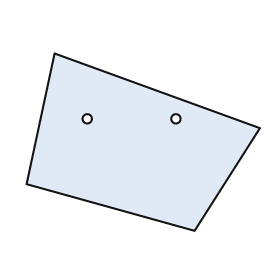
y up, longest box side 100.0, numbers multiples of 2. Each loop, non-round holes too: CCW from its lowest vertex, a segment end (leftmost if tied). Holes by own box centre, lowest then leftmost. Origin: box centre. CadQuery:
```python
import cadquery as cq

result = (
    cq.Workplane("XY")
    .moveTo(22.0, -38.0)
    .lineTo(50.0, 6.0)
    .lineTo(-38.0, 38.0)
    .lineTo(-50.0, -18.0)
    .close()
    .moveTo(-24.0, 10.0)
    .circle(2.0)
    .moveTo(14.0, 10.0)
    .circle(2.0)
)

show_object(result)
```